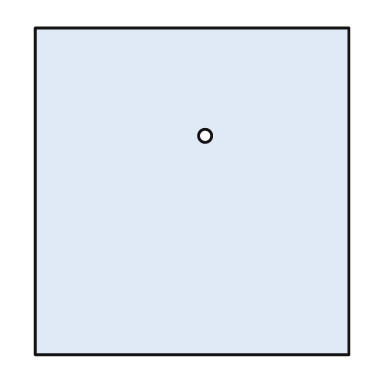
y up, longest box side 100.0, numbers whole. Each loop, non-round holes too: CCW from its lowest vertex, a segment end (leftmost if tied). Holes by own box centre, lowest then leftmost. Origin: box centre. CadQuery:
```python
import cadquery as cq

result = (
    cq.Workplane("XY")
    .moveTo(-48.0, -50.0)
    .lineTo(48.0, -50.0)
    .lineTo(48.0, 50.0)
    .lineTo(-48.0, 50.0)
    .close()
    .moveTo(4.0, 17.0)
    .circle(2.0)
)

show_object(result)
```